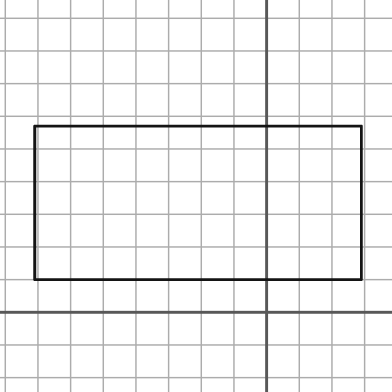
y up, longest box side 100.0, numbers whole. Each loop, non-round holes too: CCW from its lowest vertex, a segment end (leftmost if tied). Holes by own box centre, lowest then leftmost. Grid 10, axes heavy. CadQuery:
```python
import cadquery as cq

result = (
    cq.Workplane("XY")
    .moveTo(-71.0, 10.0)
    .lineTo(29.0, 10.0)
    .lineTo(29.0, 57.0)
    .lineTo(-71.0, 57.0)
    .close()
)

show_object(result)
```